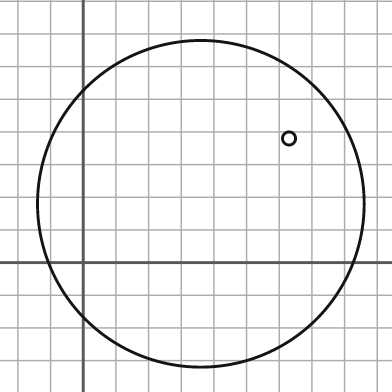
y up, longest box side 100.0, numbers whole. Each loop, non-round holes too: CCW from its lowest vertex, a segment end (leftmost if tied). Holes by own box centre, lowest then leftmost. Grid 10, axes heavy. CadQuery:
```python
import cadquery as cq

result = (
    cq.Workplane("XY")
    .moveTo(36.0, 18.0)
    .circle(50.0)
    .moveTo(63.0, 38.0)
    .circle(2.0)
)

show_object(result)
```